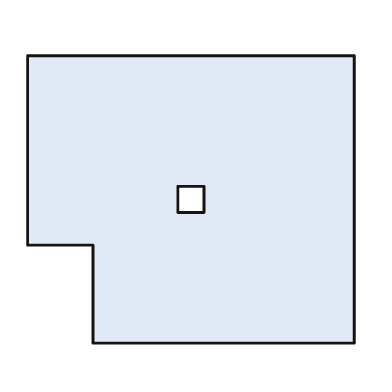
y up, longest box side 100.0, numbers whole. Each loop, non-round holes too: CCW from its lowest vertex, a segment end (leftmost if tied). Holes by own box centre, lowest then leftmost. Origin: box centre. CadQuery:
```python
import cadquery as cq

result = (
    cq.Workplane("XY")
    .moveTo(-30.0, -44.0)
    .lineTo(50.0, -44.0)
    .lineTo(50.0, 44.0)
    .lineTo(-50.0, 44.0)
    .lineTo(-50.0, -14.0)
    .lineTo(-30.0, -14.0)
    .close()
    .moveTo(-4.0, -4.0)
    .lineTo(4.0, -4.0)
    .lineTo(4.0, 4.0)
    .lineTo(-4.0, 4.0)
    .close()
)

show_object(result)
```